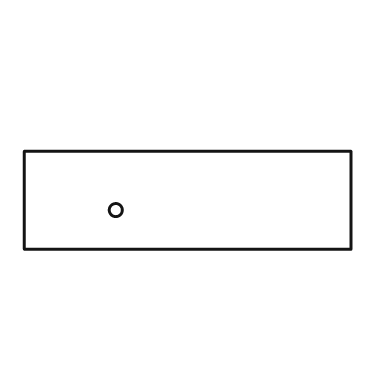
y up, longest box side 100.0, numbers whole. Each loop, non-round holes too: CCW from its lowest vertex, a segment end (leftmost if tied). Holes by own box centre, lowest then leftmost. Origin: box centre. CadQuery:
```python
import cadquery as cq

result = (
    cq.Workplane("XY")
    .moveTo(-50.0, -15.0)
    .lineTo(50.0, -15.0)
    .lineTo(50.0, 15.0)
    .lineTo(-50.0, 15.0)
    .close()
    .moveTo(-22.0, -3.0)
    .circle(2.0)
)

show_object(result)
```